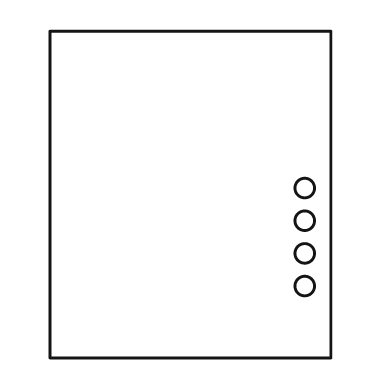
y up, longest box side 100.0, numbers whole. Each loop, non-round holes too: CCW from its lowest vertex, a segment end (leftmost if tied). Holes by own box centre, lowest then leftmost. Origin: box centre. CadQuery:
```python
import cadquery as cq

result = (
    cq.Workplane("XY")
    .moveTo(-43.0, -50.0)
    .lineTo(43.0, -50.0)
    .lineTo(43.0, 50.0)
    .lineTo(-43.0, 50.0)
    .close()
    .moveTo(35.0, -28.0)
    .circle(3.0)
    .moveTo(35.0, -18.0)
    .circle(3.0)
    .moveTo(35.0, -8.0)
    .circle(3.0)
    .moveTo(35.0, 2.0)
    .circle(3.0)
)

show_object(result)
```